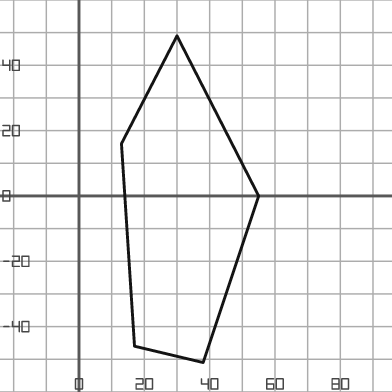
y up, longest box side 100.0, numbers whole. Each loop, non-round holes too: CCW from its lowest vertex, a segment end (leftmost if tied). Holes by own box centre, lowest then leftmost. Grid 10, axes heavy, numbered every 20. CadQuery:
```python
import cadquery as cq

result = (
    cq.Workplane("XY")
    .moveTo(38.0, -51.0)
    .lineTo(55.0, 0.0)
    .lineTo(30.0, 49.0)
    .lineTo(13.0, 16.0)
    .lineTo(17.0, -46.0)
    .close()
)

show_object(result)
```